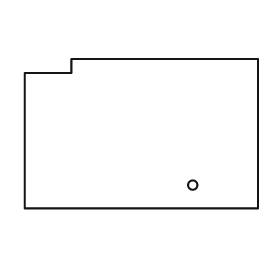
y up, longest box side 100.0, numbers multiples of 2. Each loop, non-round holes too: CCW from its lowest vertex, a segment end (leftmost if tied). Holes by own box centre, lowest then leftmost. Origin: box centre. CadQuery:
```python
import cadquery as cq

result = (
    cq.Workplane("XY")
    .moveTo(-50.0, -32.0)
    .lineTo(50.0, -32.0)
    .lineTo(50.0, 32.0)
    .lineTo(-30.0, 32.0)
    .lineTo(-30.0, 26.0)
    .lineTo(-50.0, 26.0)
    .close()
    .moveTo(22.0, -22.0)
    .circle(2.0)
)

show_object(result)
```